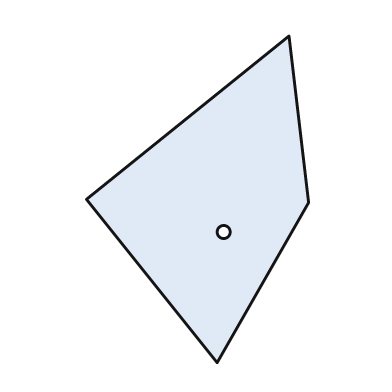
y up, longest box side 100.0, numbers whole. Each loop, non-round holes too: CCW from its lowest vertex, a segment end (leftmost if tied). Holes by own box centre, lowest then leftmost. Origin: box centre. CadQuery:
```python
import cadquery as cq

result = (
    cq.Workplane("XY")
    .moveTo(6.0, -50.0)
    .lineTo(34.0, -1.0)
    .lineTo(28.0, 50.0)
    .lineTo(-34.0, 0.0)
    .close()
    .moveTo(8.0, -10.0)
    .circle(2.0)
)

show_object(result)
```